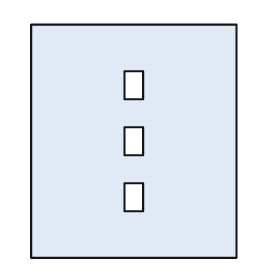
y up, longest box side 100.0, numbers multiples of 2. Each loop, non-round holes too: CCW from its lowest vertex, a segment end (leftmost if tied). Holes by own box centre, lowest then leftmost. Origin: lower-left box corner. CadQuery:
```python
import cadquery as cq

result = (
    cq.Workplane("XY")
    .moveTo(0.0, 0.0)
    .lineTo(88.0, 0.0)
    .lineTo(88.0, 100.0)
    .lineTo(0.0, 100.0)
    .close()
    .moveTo(40.0, 20.0)
    .lineTo(48.0, 20.0)
    .lineTo(48.0, 32.0)
    .lineTo(40.0, 32.0)
    .close()
    .moveTo(40.0, 44.0)
    .lineTo(48.0, 44.0)
    .lineTo(48.0, 56.0)
    .lineTo(40.0, 56.0)
    .close()
    .moveTo(40.0, 68.0)
    .lineTo(48.0, 68.0)
    .lineTo(48.0, 80.0)
    .lineTo(40.0, 80.0)
    .close()
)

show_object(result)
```